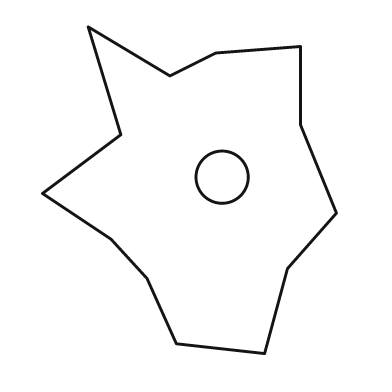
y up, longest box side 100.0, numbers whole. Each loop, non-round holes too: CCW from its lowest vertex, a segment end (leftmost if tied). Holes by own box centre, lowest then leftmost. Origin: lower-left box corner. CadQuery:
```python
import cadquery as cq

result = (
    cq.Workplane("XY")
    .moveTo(68.0, 0.0)
    .lineTo(75.0, 26.0)
    .lineTo(90.0, 43.0)
    .lineTo(79.0, 70.0)
    .lineTo(79.0, 94.0)
    .lineTo(53.0, 92.0)
    .lineTo(39.0, 85.0)
    .lineTo(14.0, 100.0)
    .lineTo(24.0, 67.0)
    .lineTo(0.0, 49.0)
    .lineTo(21.0, 35.0)
    .lineTo(32.0, 23.0)
    .lineTo(41.0, 3.0)
    .close()
    .moveTo(55.0, 54.0)
    .circle(8.0)
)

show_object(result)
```